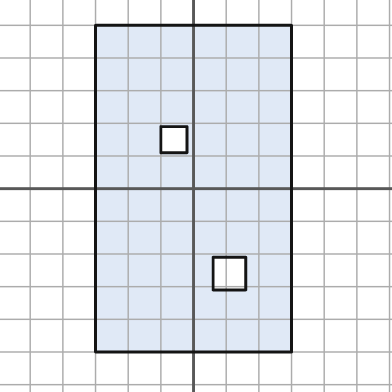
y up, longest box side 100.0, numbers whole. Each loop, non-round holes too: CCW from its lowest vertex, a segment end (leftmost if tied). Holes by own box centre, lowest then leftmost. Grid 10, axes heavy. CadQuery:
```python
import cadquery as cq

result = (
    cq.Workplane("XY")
    .moveTo(-30.0, -50.0)
    .lineTo(30.0, -50.0)
    .lineTo(30.0, 50.0)
    .lineTo(-30.0, 50.0)
    .close()
    .moveTo(6.0, -31.0)
    .lineTo(16.0, -31.0)
    .lineTo(16.0, -21.0)
    .lineTo(6.0, -21.0)
    .close()
    .moveTo(-10.0, 11.0)
    .lineTo(-2.0, 11.0)
    .lineTo(-2.0, 19.0)
    .lineTo(-10.0, 19.0)
    .close()
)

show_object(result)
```